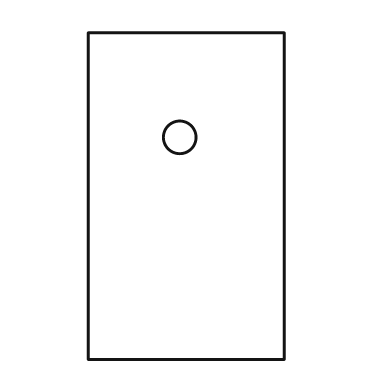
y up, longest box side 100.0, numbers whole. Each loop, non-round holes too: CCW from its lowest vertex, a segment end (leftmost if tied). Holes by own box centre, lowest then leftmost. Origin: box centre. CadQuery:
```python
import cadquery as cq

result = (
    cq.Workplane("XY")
    .moveTo(-30.0, -50.0)
    .lineTo(30.0, -50.0)
    .lineTo(30.0, 50.0)
    .lineTo(-30.0, 50.0)
    .close()
    .moveTo(-2.0, 18.0)
    .circle(5.0)
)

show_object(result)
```